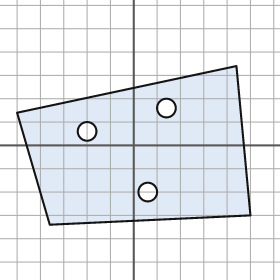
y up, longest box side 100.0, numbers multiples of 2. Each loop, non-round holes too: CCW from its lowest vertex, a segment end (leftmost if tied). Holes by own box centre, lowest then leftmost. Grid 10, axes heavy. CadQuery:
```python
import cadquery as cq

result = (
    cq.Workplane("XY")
    .moveTo(-36.0, -34.0)
    .lineTo(50.0, -30.0)
    .lineTo(44.0, 34.0)
    .lineTo(-50.0, 14.0)
    .close()
    .moveTo(6.0, -20.0)
    .circle(4.0)
    .moveTo(-20.0, 6.0)
    .circle(4.0)
    .moveTo(14.0, 16.0)
    .circle(4.0)
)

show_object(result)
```